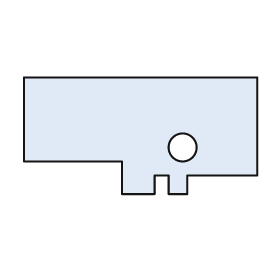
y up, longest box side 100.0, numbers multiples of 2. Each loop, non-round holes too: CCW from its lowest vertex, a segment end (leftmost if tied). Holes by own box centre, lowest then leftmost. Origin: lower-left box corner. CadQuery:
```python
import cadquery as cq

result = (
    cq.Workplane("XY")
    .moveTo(42.0, 0.0)
    .lineTo(56.0, 0.0)
    .lineTo(56.0, 8.0)
    .lineTo(62.0, 8.0)
    .lineTo(62.0, 0.0)
    .lineTo(70.0, 0.0)
    .lineTo(70.0, 8.0)
    .lineTo(100.0, 8.0)
    .lineTo(100.0, 50.0)
    .lineTo(0.0, 50.0)
    .lineTo(0.0, 14.0)
    .lineTo(42.0, 14.0)
    .close()
    .moveTo(68.0, 20.0)
    .circle(6.0)
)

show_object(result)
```